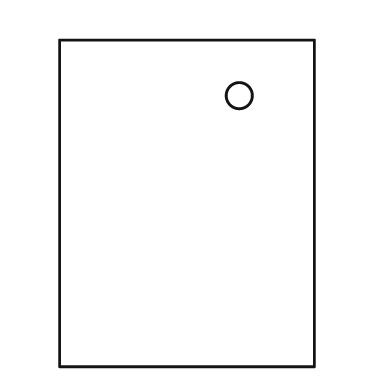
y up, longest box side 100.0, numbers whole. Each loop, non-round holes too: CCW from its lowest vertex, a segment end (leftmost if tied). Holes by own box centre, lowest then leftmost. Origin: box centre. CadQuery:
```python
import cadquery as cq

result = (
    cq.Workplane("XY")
    .moveTo(-39.0, -50.0)
    .lineTo(39.0, -50.0)
    .lineTo(39.0, 50.0)
    .lineTo(-39.0, 50.0)
    .close()
    .moveTo(16.0, 33.0)
    .circle(4.0)
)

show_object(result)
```